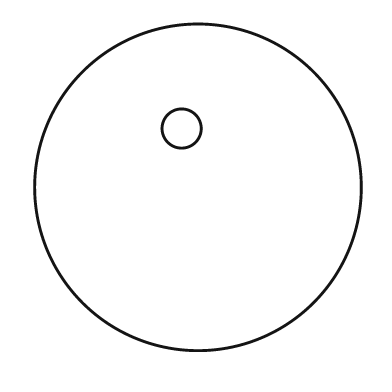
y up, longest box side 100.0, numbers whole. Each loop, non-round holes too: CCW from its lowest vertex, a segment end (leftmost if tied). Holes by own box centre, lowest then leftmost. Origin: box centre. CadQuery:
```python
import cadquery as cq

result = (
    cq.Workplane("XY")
    .moveTo(0.0, 0.0)
    .circle(50.0)
    .moveTo(-5.0, 18.0)
    .circle(6.0)
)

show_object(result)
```